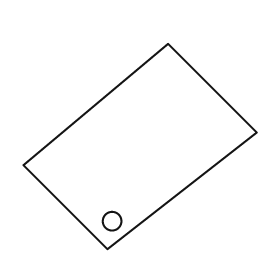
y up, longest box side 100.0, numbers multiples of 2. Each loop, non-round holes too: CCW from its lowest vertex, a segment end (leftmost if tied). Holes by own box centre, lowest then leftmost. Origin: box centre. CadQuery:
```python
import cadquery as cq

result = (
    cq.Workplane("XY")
    .moveTo(-14.0, -44.0)
    .lineTo(50.0, 6.0)
    .lineTo(12.0, 44.0)
    .lineTo(-50.0, -8.0)
    .close()
    .moveTo(-12.0, -32.0)
    .circle(4.0)
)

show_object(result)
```